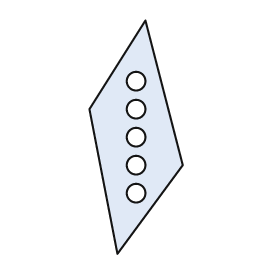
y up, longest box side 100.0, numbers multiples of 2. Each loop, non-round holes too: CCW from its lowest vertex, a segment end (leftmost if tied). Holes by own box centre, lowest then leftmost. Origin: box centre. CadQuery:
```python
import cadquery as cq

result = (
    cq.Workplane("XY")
    .moveTo(-8.0, -50.0)
    .lineTo(20.0, -12.0)
    .lineTo(4.0, 50.0)
    .lineTo(-20.0, 12.0)
    .close()
    .moveTo(0.0, -24.0)
    .circle(4.0)
    .moveTo(0.0, -12.0)
    .circle(4.0)
    .moveTo(0.0, 0.0)
    .circle(4.0)
    .moveTo(0.0, 12.0)
    .circle(4.0)
    .moveTo(0.0, 24.0)
    .circle(4.0)
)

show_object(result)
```